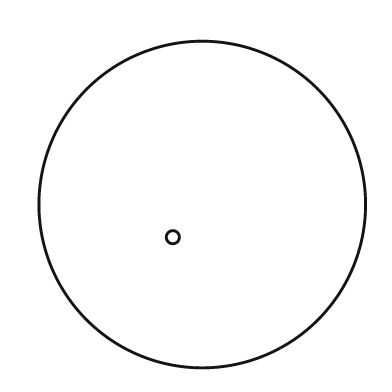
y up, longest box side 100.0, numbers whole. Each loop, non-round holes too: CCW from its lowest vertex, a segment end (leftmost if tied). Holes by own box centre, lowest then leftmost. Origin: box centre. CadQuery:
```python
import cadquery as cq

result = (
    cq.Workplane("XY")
    .moveTo(0.0, 0.0)
    .circle(50.0)
    .moveTo(-9.0, -10.0)
    .circle(2.0)
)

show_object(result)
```